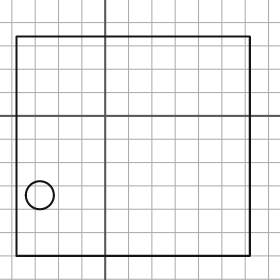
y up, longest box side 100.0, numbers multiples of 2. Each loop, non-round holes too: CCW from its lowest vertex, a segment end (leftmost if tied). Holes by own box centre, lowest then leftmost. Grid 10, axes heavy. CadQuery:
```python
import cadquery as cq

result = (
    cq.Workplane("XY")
    .moveTo(-38.0, -60.0)
    .lineTo(62.0, -60.0)
    .lineTo(62.0, 34.0)
    .lineTo(-38.0, 34.0)
    .close()
    .moveTo(-28.0, -34.0)
    .circle(6.0)
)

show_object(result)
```